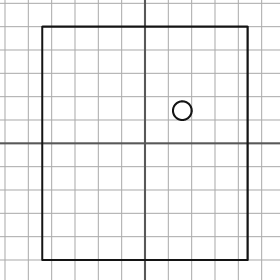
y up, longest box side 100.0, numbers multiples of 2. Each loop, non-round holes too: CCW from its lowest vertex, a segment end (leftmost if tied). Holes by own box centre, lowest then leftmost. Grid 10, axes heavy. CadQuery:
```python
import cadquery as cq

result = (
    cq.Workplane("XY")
    .moveTo(-44.0, -50.0)
    .lineTo(44.0, -50.0)
    .lineTo(44.0, 50.0)
    .lineTo(-44.0, 50.0)
    .close()
    .moveTo(16.0, 14.0)
    .circle(4.0)
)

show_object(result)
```